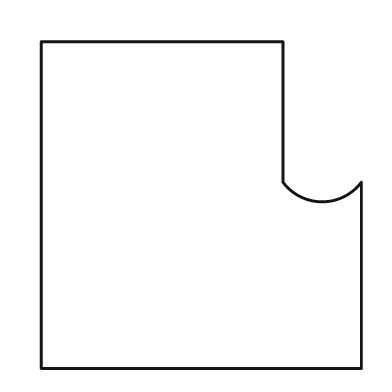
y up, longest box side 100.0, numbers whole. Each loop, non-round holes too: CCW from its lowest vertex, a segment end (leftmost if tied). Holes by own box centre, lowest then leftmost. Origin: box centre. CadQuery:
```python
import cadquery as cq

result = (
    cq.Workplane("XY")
    .moveTo(-49.0, -50.0)
    .lineTo(49.0, -50.0)
    .lineTo(49.0, 7.0)
    .threePointArc((37.0, 1.0), (25.0, 7.0))
    .lineTo(25.0, 50.0)
    .lineTo(-49.0, 50.0)
    .close()
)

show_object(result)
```